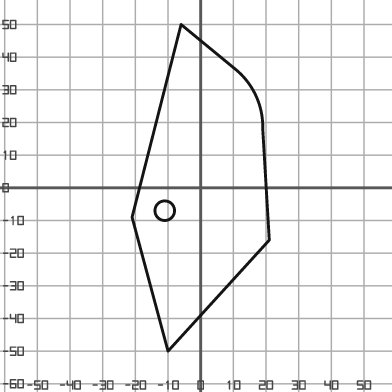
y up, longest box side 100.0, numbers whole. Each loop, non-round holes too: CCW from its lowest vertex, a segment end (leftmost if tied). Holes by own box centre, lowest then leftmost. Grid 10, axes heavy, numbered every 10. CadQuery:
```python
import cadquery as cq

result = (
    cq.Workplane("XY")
    .moveTo(-10.0, -50.0)
    .lineTo(21.0, -16.0)
    .lineTo(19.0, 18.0)
    .threePointArc((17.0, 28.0), (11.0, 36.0))
    .lineTo(-6.0, 50.0)
    .lineTo(-21.0, -9.0)
    .close()
    .moveTo(-11.0, -7.0)
    .circle(3.0)
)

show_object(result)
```